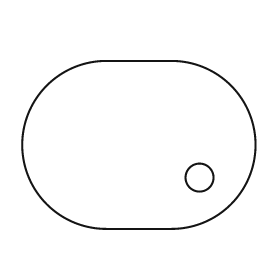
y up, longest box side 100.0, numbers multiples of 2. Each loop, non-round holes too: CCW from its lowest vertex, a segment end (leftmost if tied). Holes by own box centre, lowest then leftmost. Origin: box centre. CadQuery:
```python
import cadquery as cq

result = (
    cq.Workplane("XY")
    .moveTo(-14.0, -36.0)
    .lineTo(14.0, -36.0)
    .threePointArc((50.0, 0.0), (14.0, 36.0))
    .lineTo(-14.0, 36.0)
    .threePointArc((-50.0, 0.0), (-14.0, -36.0))
    .close()
    .moveTo(26.0, -14.0)
    .circle(6.0)
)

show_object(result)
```